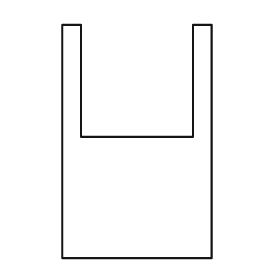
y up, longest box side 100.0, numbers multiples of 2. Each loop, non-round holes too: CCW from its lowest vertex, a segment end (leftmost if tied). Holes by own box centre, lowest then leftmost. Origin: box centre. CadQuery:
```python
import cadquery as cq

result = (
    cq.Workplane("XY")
    .moveTo(-32.0, -50.0)
    .lineTo(32.0, -50.0)
    .lineTo(32.0, 50.0)
    .lineTo(24.0, 50.0)
    .lineTo(24.0, 2.0)
    .lineTo(-24.0, 2.0)
    .lineTo(-24.0, 50.0)
    .lineTo(-32.0, 50.0)
    .close()
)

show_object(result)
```